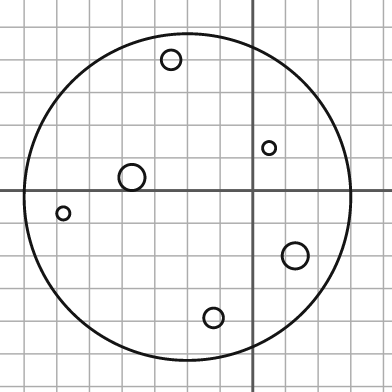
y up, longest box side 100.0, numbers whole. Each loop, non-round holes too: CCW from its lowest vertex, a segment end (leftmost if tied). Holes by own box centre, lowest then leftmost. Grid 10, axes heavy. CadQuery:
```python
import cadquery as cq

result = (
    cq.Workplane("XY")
    .moveTo(-20.0, -2.0)
    .circle(50.0)
    .moveTo(-12.0, -39.0)
    .circle(3.0)
    .moveTo(13.0, -20.0)
    .circle(4.0)
    .moveTo(-58.0, -7.0)
    .circle(2.0)
    .moveTo(-37.0, 4.0)
    .circle(4.0)
    .moveTo(5.0, 13.0)
    .circle(2.0)
    .moveTo(-25.0, 40.0)
    .circle(3.0)
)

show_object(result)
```